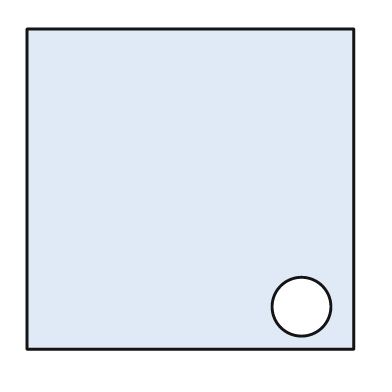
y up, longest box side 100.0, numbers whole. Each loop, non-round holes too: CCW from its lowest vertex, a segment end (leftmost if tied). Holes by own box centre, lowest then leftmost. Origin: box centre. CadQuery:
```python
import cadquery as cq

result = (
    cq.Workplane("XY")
    .moveTo(-50.0, -49.0)
    .lineTo(50.0, -49.0)
    .lineTo(50.0, 49.0)
    .lineTo(-50.0, 49.0)
    .close()
    .moveTo(34.0, -36.0)
    .circle(9.0)
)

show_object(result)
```